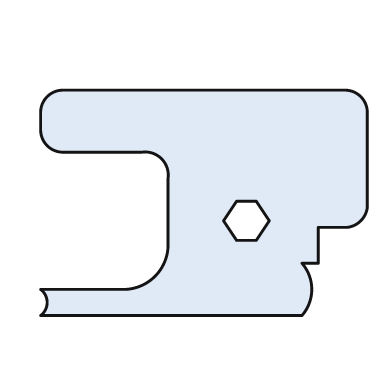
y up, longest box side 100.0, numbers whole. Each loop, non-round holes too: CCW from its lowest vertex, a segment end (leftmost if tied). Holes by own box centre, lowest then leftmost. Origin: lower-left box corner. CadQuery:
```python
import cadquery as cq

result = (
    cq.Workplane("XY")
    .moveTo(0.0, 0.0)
    .lineTo(80.0, 0.0)
    .threePointArc((83.0, 8.0), (80.0, 16.0))
    .lineTo(85.0, 16.0)
    .lineTo(85.0, 27.0)
    .lineTo(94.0, 27.0)
    .threePointArc((98.0, 29.0), (100.0, 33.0))
    .lineTo(100.0, 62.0)
    .threePointArc((98.0, 67.0), (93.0, 69.0))
    .lineTo(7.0, 69.0)
    .threePointArc((2.0, 67.0), (0.0, 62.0))
    .lineTo(0.0, 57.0)
    .threePointArc((2.0, 52.0), (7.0, 50.0))
    .lineTo(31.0, 50.0)
    .threePointArc((37.0, 48.0), (39.0, 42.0))
    .lineTo(39.0, 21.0)
    .threePointArc((35.0, 12.0), (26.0, 8.0))
    .lineTo(0.0, 8.0)
    .threePointArc((2.0, 4.0), (0.0, 0.0))
    .close()
    .moveTo(60.0, 23.0)
    .lineTo(66.0, 23.0)
    .lineTo(70.0, 29.0)
    .lineTo(66.0, 35.0)
    .lineTo(60.0, 35.0)
    .lineTo(56.0, 29.0)
    .close()
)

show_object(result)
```